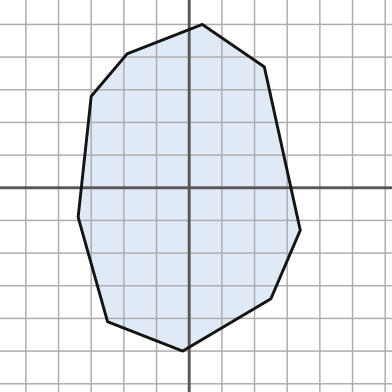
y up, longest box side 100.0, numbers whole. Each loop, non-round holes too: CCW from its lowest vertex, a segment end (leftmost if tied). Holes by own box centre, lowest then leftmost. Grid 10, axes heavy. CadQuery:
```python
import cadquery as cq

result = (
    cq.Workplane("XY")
    .moveTo(-2.0, -50.0)
    .lineTo(25.0, -34.0)
    .lineTo(34.0, -13.0)
    .lineTo(23.0, 37.0)
    .lineTo(4.0, 50.0)
    .lineTo(-19.0, 41.0)
    .lineTo(-30.0, 28.0)
    .lineTo(-34.0, -9.0)
    .lineTo(-25.0, -41.0)
    .close()
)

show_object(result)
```